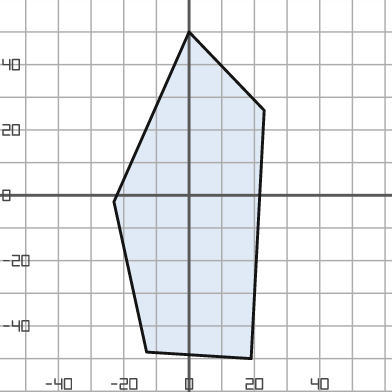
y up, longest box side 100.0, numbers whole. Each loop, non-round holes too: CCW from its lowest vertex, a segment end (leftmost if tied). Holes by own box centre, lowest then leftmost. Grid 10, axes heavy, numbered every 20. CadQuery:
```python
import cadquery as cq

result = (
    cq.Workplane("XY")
    .moveTo(19.0, -50.0)
    .lineTo(23.0, 26.0)
    .lineTo(0.0, 50.0)
    .lineTo(-23.0, -2.0)
    .lineTo(-13.0, -48.0)
    .close()
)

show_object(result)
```